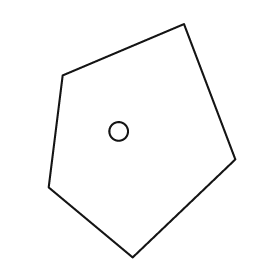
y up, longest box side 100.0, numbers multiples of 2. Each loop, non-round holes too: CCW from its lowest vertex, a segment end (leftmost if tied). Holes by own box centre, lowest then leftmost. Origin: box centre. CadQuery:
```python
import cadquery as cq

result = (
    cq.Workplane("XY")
    .moveTo(-4.0, -50.0)
    .lineTo(40.0, -8.0)
    .lineTo(18.0, 50.0)
    .lineTo(-34.0, 28.0)
    .lineTo(-40.0, -20.0)
    .close()
    .moveTo(-10.0, 4.0)
    .circle(4.0)
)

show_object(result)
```